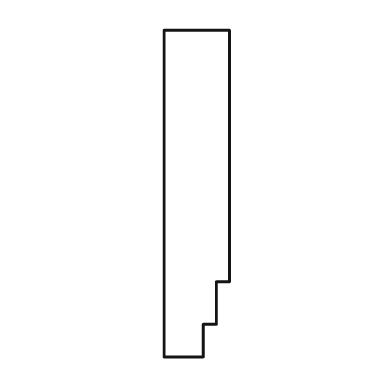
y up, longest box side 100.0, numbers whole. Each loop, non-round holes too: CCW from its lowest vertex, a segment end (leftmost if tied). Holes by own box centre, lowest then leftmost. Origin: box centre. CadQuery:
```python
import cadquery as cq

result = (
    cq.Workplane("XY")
    .moveTo(-10.0, -50.0)
    .lineTo(2.0, -50.0)
    .lineTo(2.0, -40.0)
    .lineTo(6.0, -40.0)
    .lineTo(6.0, -27.0)
    .lineTo(10.0, -27.0)
    .lineTo(10.0, 50.0)
    .lineTo(-10.0, 50.0)
    .close()
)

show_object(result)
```